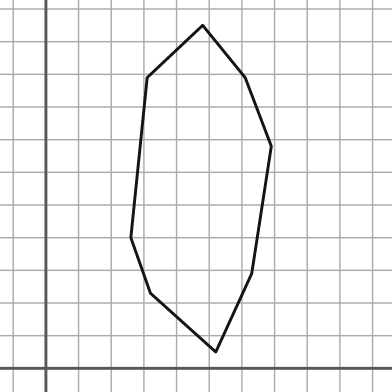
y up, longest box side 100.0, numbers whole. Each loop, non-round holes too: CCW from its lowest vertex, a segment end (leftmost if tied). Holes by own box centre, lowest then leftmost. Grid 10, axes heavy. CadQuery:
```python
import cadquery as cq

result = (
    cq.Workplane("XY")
    .moveTo(52.0, 5.0)
    .lineTo(63.0, 29.0)
    .lineTo(69.0, 68.0)
    .lineTo(61.0, 89.0)
    .lineTo(48.0, 105.0)
    .lineTo(31.0, 89.0)
    .lineTo(26.0, 40.0)
    .lineTo(32.0, 23.0)
    .close()
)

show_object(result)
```